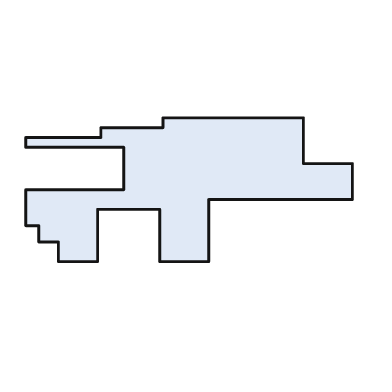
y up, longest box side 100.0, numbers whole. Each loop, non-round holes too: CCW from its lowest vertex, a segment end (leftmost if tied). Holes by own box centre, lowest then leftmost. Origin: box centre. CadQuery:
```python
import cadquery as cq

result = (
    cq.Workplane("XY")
    .moveTo(-40.0, -22.0)
    .lineTo(-28.0, -22.0)
    .lineTo(-28.0, -6.0)
    .lineTo(-9.0, -6.0)
    .lineTo(-9.0, -22.0)
    .lineTo(6.0, -22.0)
    .lineTo(6.0, -3.0)
    .lineTo(50.0, -3.0)
    .lineTo(50.0, 8.0)
    .lineTo(35.0, 8.0)
    .lineTo(35.0, 22.0)
    .lineTo(-8.0, 22.0)
    .lineTo(-8.0, 19.0)
    .lineTo(-27.0, 19.0)
    .lineTo(-27.0, 16.0)
    .lineTo(-50.0, 16.0)
    .lineTo(-50.0, 13.0)
    .lineTo(-20.0, 13.0)
    .lineTo(-20.0, 0.0)
    .lineTo(-50.0, 0.0)
    .lineTo(-50.0, -11.0)
    .lineTo(-46.0, -11.0)
    .lineTo(-46.0, -16.0)
    .lineTo(-40.0, -16.0)
    .close()
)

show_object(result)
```